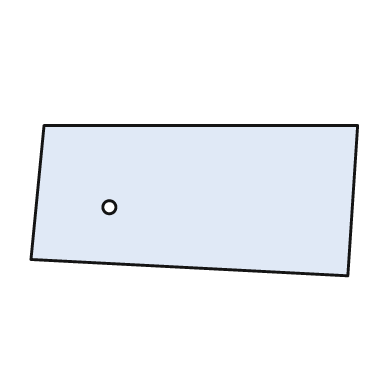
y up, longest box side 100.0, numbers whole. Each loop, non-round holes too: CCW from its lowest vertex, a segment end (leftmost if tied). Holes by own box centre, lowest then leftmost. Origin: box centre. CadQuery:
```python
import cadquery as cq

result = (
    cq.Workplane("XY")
    .moveTo(47.0, -23.0)
    .lineTo(50.0, 23.0)
    .lineTo(-46.0, 23.0)
    .lineTo(-50.0, -18.0)
    .close()
    .moveTo(-26.0, -2.0)
    .circle(2.0)
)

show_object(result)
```